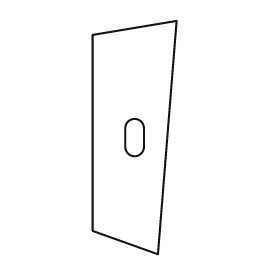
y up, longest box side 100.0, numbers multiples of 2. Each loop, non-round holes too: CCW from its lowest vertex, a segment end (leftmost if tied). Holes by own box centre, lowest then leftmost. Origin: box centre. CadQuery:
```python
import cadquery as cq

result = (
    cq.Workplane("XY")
    .moveTo(10.0, -50.0)
    .lineTo(18.0, 50.0)
    .lineTo(-18.0, 44.0)
    .lineTo(-18.0, -40.0)
    .close()
    .moveTo(-4.0, -4.0)
    .threePointArc((0.0, -8.0), (4.0, -4.0))
    .lineTo(4.0, 4.0)
    .threePointArc((0.0, 8.0), (-4.0, 4.0))
    .close()
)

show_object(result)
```